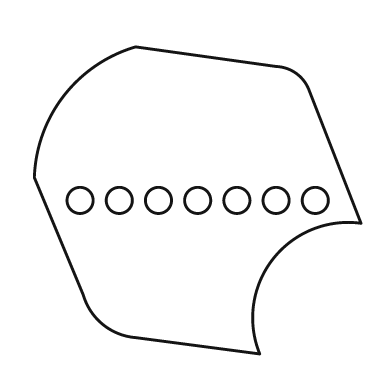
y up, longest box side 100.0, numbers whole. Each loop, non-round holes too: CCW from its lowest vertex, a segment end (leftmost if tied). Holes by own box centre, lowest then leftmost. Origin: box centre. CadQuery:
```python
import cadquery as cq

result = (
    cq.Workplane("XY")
    .moveTo(19.0, -47.0)
    .threePointArc((23.0, -18.0), (50.0, -7.0))
    .lineTo(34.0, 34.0)
    .threePointArc((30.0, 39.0), (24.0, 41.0))
    .lineTo(-19.0, 47.0)
    .threePointArc((-41.0, 32.0), (-50.0, 7.0))
    .lineTo(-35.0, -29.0)
    .threePointArc((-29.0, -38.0), (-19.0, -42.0))
    .close()
    .moveTo(-36.0, 0.0)
    .circle(4.0)
    .moveTo(-24.0, 0.0)
    .circle(4.0)
    .moveTo(-12.0, 0.0)
    .circle(4.0)
    .moveTo(0.0, 0.0)
    .circle(4.0)
    .moveTo(12.0, 0.0)
    .circle(4.0)
    .moveTo(24.0, 0.0)
    .circle(4.0)
    .moveTo(36.0, 0.0)
    .circle(4.0)
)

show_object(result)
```